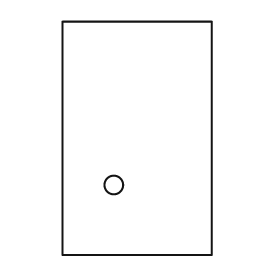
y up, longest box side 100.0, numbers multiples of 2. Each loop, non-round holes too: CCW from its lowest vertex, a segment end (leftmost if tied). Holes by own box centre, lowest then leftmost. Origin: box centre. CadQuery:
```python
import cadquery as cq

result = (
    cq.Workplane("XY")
    .moveTo(-32.0, -50.0)
    .lineTo(32.0, -50.0)
    .lineTo(32.0, 50.0)
    .lineTo(-32.0, 50.0)
    .close()
    .moveTo(-10.0, -20.0)
    .circle(4.0)
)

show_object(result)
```